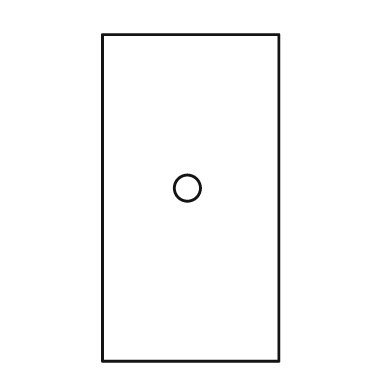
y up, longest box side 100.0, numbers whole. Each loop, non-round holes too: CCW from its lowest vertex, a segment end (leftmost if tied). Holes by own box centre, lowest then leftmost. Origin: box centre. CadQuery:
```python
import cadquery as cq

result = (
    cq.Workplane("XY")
    .moveTo(-27.0, -50.0)
    .lineTo(27.0, -50.0)
    .lineTo(27.0, 50.0)
    .lineTo(-27.0, 50.0)
    .close()
    .moveTo(-1.0, 3.0)
    .circle(4.0)
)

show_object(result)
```